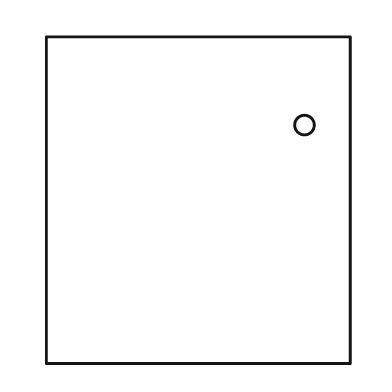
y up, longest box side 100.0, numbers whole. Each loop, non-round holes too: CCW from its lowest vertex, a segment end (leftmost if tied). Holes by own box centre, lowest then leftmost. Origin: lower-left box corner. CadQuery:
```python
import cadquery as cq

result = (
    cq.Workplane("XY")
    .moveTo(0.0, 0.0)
    .lineTo(93.0, 0.0)
    .lineTo(93.0, 100.0)
    .lineTo(0.0, 100.0)
    .close()
    .moveTo(79.0, 73.0)
    .circle(3.0)
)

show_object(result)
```